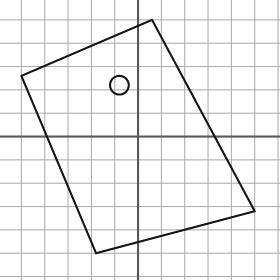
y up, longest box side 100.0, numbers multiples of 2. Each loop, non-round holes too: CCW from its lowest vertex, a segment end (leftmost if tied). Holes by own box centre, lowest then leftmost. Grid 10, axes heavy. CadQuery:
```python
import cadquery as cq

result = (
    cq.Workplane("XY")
    .moveTo(-18.0, -50.0)
    .lineTo(50.0, -32.0)
    .lineTo(6.0, 50.0)
    .lineTo(-50.0, 26.0)
    .close()
    .moveTo(-8.0, 22.0)
    .circle(4.0)
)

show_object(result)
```